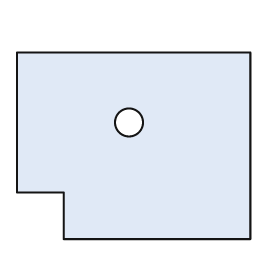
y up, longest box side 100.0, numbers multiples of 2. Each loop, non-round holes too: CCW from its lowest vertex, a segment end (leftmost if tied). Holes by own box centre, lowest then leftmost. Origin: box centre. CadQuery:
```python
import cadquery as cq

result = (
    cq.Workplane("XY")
    .moveTo(-30.0, -40.0)
    .lineTo(50.0, -40.0)
    .lineTo(50.0, 40.0)
    .lineTo(-50.0, 40.0)
    .lineTo(-50.0, -20.0)
    .lineTo(-30.0, -20.0)
    .close()
    .moveTo(-2.0, 10.0)
    .circle(6.0)
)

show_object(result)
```